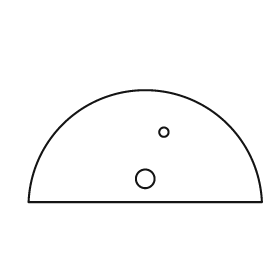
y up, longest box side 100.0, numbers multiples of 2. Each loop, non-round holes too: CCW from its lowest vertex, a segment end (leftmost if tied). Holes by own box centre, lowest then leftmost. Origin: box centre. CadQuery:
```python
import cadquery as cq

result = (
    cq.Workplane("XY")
    .moveTo(-50.0, -24.0)
    .lineTo(50.0, -24.0)
    .threePointArc((0.0, 24.0), (-50.0, -24.0))
    .close()
    .moveTo(0.0, -14.0)
    .circle(4.0)
    .moveTo(8.0, 6.0)
    .circle(2.0)
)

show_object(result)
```